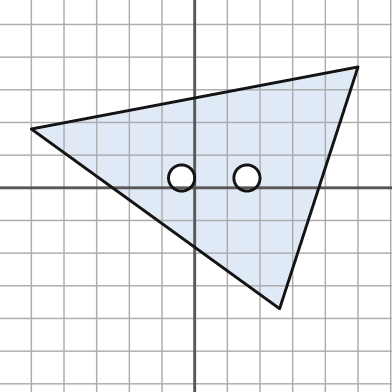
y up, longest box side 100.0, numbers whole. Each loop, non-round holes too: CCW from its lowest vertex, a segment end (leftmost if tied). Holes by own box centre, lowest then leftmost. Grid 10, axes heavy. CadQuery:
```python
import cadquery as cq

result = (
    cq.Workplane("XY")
    .moveTo(26.0, -37.0)
    .lineTo(50.0, 37.0)
    .lineTo(-50.0, 18.0)
    .close()
    .moveTo(-4.0, 3.0)
    .circle(4.0)
    .moveTo(16.0, 3.0)
    .circle(4.0)
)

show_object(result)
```